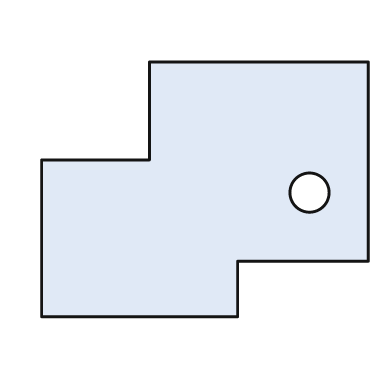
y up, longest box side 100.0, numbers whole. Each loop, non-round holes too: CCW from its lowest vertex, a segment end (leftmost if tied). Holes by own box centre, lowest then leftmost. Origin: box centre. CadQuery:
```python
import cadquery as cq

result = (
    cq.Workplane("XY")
    .moveTo(-50.0, -39.0)
    .lineTo(10.0, -39.0)
    .lineTo(10.0, -22.0)
    .lineTo(50.0, -22.0)
    .lineTo(50.0, 39.0)
    .lineTo(-17.0, 39.0)
    .lineTo(-17.0, 9.0)
    .lineTo(-50.0, 9.0)
    .close()
    .moveTo(32.0, -1.0)
    .circle(6.0)
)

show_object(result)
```